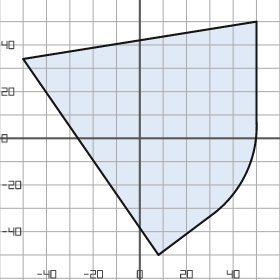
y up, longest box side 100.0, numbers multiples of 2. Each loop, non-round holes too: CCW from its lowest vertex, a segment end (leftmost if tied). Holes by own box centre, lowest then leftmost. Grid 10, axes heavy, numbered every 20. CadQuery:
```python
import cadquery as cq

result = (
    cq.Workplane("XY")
    .moveTo(8.0, -50.0)
    .lineTo(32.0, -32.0)
    .threePointArc((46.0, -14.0), (50.0, 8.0))
    .lineTo(50.0, 50.0)
    .lineTo(-50.0, 34.0)
    .close()
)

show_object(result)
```